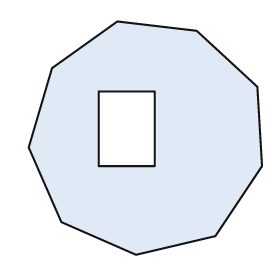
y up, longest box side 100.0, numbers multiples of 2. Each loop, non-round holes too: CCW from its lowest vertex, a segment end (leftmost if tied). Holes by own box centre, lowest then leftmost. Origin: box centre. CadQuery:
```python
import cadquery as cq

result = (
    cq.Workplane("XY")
    .moveTo(-4.0, -50.0)
    .lineTo(30.0, -42.0)
    .lineTo(50.0, -12.0)
    .lineTo(48.0, 22.0)
    .lineTo(22.0, 46.0)
    .lineTo(-12.0, 50.0)
    .lineTo(-40.0, 30.0)
    .lineTo(-50.0, -4.0)
    .lineTo(-36.0, -36.0)
    .close()
    .moveTo(-20.0, -12.0)
    .lineTo(4.0, -12.0)
    .lineTo(4.0, 20.0)
    .lineTo(-20.0, 20.0)
    .close()
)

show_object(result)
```